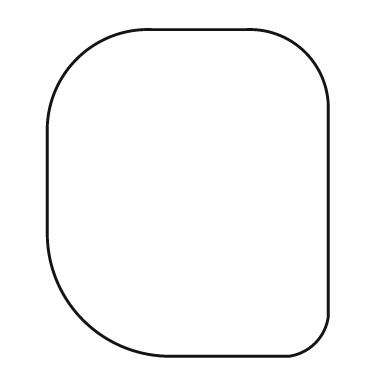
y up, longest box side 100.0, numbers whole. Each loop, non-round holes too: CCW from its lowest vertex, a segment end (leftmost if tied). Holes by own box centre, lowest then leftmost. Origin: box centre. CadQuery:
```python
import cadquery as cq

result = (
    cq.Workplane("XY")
    .moveTo(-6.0, -50.0)
    .lineTo(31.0, -50.0)
    .threePointArc((39.0, -46.0), (43.0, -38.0))
    .lineTo(43.0, 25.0)
    .threePointArc((36.0, 43.0), (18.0, 50.0))
    .lineTo(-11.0, 50.0)
    .threePointArc((-34.0, 41.0), (-43.0, 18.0))
    .lineTo(-43.0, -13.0)
    .threePointArc((-32.0, -39.0), (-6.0, -50.0))
    .close()
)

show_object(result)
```